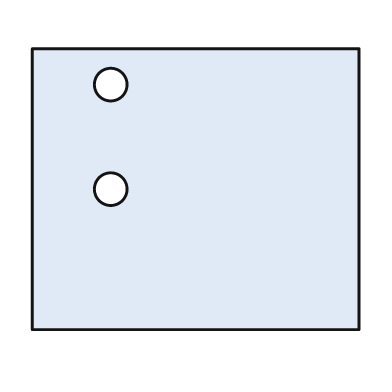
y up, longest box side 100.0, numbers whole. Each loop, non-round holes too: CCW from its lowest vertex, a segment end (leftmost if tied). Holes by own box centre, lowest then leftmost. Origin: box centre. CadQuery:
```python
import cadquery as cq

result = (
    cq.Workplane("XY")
    .moveTo(-50.0, -43.0)
    .lineTo(50.0, -43.0)
    .lineTo(50.0, 43.0)
    .lineTo(-50.0, 43.0)
    .close()
    .moveTo(-26.0, 0.0)
    .circle(5.0)
    .moveTo(-26.0, 32.0)
    .circle(5.0)
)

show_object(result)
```